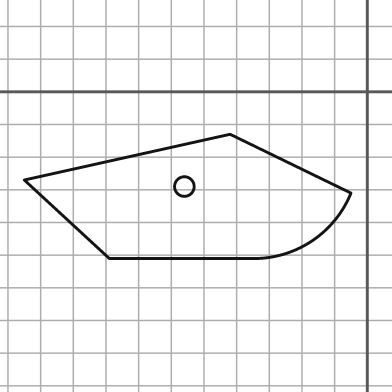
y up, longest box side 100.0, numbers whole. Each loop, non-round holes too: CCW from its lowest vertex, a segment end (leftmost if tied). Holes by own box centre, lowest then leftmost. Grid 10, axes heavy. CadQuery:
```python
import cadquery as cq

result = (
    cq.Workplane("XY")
    .moveTo(-79.0, -51.0)
    .lineTo(-33.0, -51.0)
    .threePointArc((-16.0, -45.0), (-5.0, -31.0))
    .lineTo(-42.0, -13.0)
    .lineTo(-105.0, -27.0)
    .close()
    .moveTo(-56.0, -29.0)
    .circle(3.0)
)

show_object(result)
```